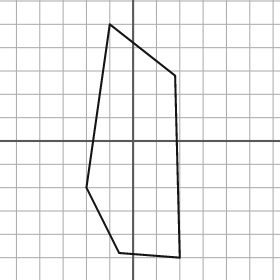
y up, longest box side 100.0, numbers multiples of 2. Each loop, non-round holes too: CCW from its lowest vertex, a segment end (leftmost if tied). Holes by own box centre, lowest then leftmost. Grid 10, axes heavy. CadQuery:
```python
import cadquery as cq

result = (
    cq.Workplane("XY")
    .moveTo(20.0, -50.0)
    .lineTo(18.0, 28.0)
    .lineTo(-10.0, 50.0)
    .lineTo(-20.0, -20.0)
    .lineTo(-6.0, -48.0)
    .close()
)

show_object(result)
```